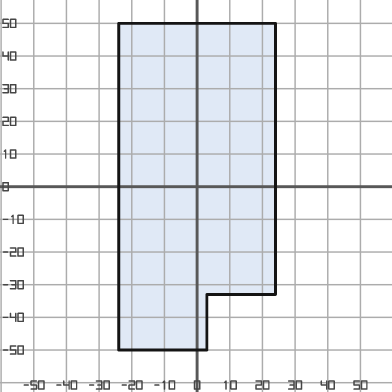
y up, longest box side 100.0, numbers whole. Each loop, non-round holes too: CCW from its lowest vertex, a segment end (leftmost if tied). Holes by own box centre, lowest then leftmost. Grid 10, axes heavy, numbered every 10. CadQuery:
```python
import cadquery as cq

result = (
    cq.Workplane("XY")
    .moveTo(-24.0, -50.0)
    .lineTo(3.0, -50.0)
    .lineTo(3.0, -33.0)
    .lineTo(24.0, -33.0)
    .lineTo(24.0, 50.0)
    .lineTo(-24.0, 50.0)
    .close()
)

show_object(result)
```